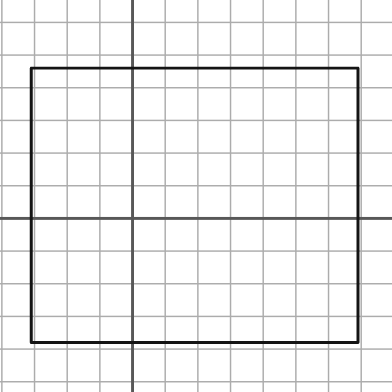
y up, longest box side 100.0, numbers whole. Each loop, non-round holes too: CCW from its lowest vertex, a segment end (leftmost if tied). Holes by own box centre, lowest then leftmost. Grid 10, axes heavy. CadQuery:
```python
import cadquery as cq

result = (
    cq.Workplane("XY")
    .moveTo(-31.0, -38.0)
    .lineTo(69.0, -38.0)
    .lineTo(69.0, 46.0)
    .lineTo(-31.0, 46.0)
    .close()
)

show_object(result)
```